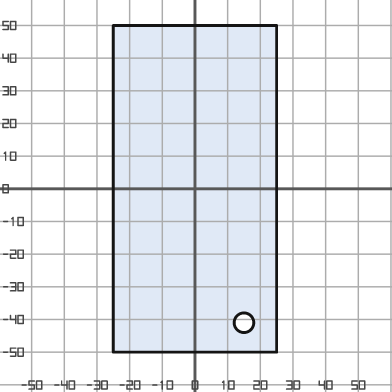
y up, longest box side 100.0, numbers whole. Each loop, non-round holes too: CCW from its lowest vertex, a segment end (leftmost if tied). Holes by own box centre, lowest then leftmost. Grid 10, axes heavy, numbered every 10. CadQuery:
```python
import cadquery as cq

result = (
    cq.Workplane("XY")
    .moveTo(-25.0, -50.0)
    .lineTo(25.0, -50.0)
    .lineTo(25.0, 50.0)
    .lineTo(-25.0, 50.0)
    .close()
    .moveTo(15.0, -41.0)
    .circle(3.0)
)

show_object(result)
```